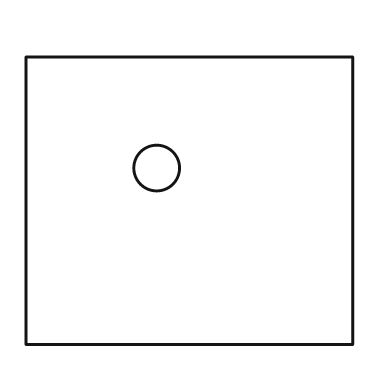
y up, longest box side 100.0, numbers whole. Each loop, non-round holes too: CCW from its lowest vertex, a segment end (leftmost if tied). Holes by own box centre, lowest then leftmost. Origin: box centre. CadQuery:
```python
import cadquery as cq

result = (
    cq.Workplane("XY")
    .moveTo(-50.0, -44.0)
    .lineTo(50.0, -44.0)
    .lineTo(50.0, 44.0)
    .lineTo(-50.0, 44.0)
    .close()
    .moveTo(-10.0, 10.0)
    .circle(7.0)
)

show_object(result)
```